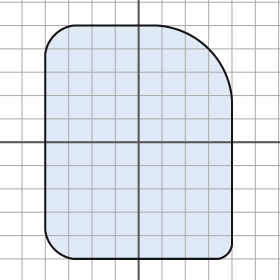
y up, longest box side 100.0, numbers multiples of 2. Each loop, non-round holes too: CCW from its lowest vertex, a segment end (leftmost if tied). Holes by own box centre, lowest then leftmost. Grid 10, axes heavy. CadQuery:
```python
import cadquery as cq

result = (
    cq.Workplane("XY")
    .moveTo(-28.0, -50.0)
    .lineTo(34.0, -50.0)
    .threePointArc((38.0, -48.0), (40.0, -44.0))
    .lineTo(40.0, 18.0)
    .threePointArc((30.0, 40.0), (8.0, 50.0))
    .lineTo(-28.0, 50.0)
    .threePointArc((-36.0, 46.0), (-40.0, 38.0))
    .lineTo(-40.0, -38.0)
    .threePointArc((-36.0, -46.0), (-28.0, -50.0))
    .close()
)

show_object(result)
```